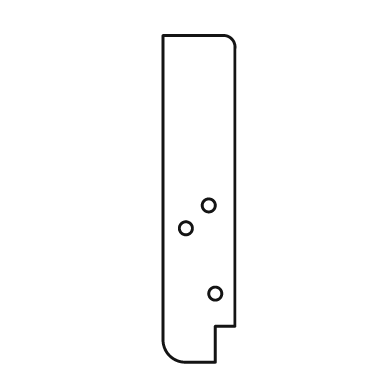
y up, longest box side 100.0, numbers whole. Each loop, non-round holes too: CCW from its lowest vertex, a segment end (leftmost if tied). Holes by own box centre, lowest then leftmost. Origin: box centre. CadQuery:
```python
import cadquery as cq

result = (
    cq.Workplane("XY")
    .moveTo(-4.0, -50.0)
    .lineTo(5.0, -50.0)
    .lineTo(5.0, -39.0)
    .lineTo(11.0, -39.0)
    .lineTo(11.0, 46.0)
    .threePointArc((10.0, 49.0), (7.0, 50.0))
    .lineTo(-11.0, 50.0)
    .lineTo(-11.0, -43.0)
    .threePointArc((-9.0, -48.0), (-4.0, -50.0))
    .close()
    .moveTo(5.0, -29.0)
    .circle(2.0)
    .moveTo(-4.0, -9.0)
    .circle(2.0)
    .moveTo(3.0, -2.0)
    .circle(2.0)
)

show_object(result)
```